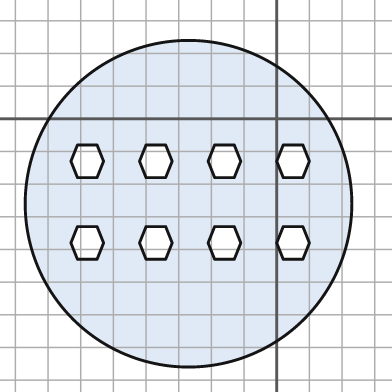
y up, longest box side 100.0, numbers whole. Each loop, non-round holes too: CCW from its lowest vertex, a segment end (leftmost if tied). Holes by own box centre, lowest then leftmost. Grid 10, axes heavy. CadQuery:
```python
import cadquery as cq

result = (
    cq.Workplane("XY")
    .moveTo(-27.0, -26.0)
    .circle(50.0)
    .moveTo(-61.0, -43.0)
    .lineTo(-55.0, -43.0)
    .lineTo(-53.0, -38.0)
    .lineTo(-55.0, -33.0)
    .lineTo(-61.0, -33.0)
    .lineTo(-63.0, -38.0)
    .close()
    .moveTo(-40.0, -43.0)
    .lineTo(-34.0, -43.0)
    .lineTo(-32.0, -38.0)
    .lineTo(-34.0, -33.0)
    .lineTo(-40.0, -33.0)
    .lineTo(-42.0, -38.0)
    .close()
    .moveTo(-19.0, -43.0)
    .lineTo(-13.0, -43.0)
    .lineTo(-11.0, -38.0)
    .lineTo(-13.0, -33.0)
    .lineTo(-19.0, -33.0)
    .lineTo(-21.0, -38.0)
    .close()
    .moveTo(2.0, -43.0)
    .lineTo(8.0, -43.0)
    .lineTo(10.0, -38.0)
    .lineTo(8.0, -33.0)
    .lineTo(2.0, -33.0)
    .lineTo(0.0, -38.0)
    .close()
    .moveTo(-61.0, -18.0)
    .lineTo(-55.0, -18.0)
    .lineTo(-53.0, -13.0)
    .lineTo(-55.0, -8.0)
    .lineTo(-61.0, -8.0)
    .lineTo(-63.0, -13.0)
    .close()
    .moveTo(-40.0, -18.0)
    .lineTo(-34.0, -18.0)
    .lineTo(-32.0, -13.0)
    .lineTo(-34.0, -8.0)
    .lineTo(-40.0, -8.0)
    .lineTo(-42.0, -13.0)
    .close()
    .moveTo(-19.0, -18.0)
    .lineTo(-13.0, -18.0)
    .lineTo(-11.0, -13.0)
    .lineTo(-13.0, -8.0)
    .lineTo(-19.0, -8.0)
    .lineTo(-21.0, -13.0)
    .close()
    .moveTo(2.0, -18.0)
    .lineTo(8.0, -18.0)
    .lineTo(10.0, -13.0)
    .lineTo(8.0, -8.0)
    .lineTo(2.0, -8.0)
    .lineTo(0.0, -13.0)
    .close()
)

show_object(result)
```